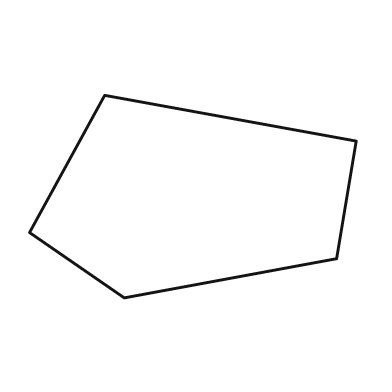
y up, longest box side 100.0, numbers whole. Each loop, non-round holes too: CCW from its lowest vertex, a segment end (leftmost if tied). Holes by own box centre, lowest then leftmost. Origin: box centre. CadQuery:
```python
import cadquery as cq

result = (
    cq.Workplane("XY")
    .moveTo(-21.0, -31.0)
    .lineTo(44.0, -19.0)
    .lineTo(50.0, 17.0)
    .lineTo(-27.0, 31.0)
    .lineTo(-50.0, -11.0)
    .close()
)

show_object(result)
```